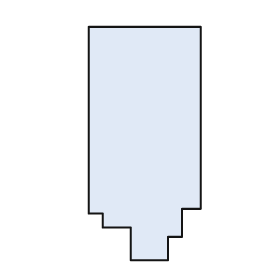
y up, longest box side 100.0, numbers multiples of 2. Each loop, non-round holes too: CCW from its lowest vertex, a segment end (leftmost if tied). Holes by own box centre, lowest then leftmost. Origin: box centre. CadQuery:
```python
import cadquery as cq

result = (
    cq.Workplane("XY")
    .moveTo(-6.0, -50.0)
    .lineTo(10.0, -50.0)
    .lineTo(10.0, -40.0)
    .lineTo(16.0, -40.0)
    .lineTo(16.0, -28.0)
    .lineTo(24.0, -28.0)
    .lineTo(24.0, 50.0)
    .lineTo(-24.0, 50.0)
    .lineTo(-24.0, -30.0)
    .lineTo(-18.0, -30.0)
    .lineTo(-18.0, -36.0)
    .lineTo(-6.0, -36.0)
    .close()
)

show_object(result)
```